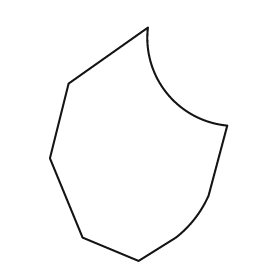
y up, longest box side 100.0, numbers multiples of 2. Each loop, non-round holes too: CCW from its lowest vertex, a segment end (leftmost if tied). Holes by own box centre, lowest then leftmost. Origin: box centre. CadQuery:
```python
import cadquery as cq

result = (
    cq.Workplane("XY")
    .moveTo(0.0, -50.0)
    .lineTo(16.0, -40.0)
    .threePointArc((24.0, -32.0), (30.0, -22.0))
    .lineTo(38.0, 8.0)
    .threePointArc((12.0, 22.0), (4.0, 50.0))
    .lineTo(-30.0, 26.0)
    .lineTo(-38.0, -6.0)
    .lineTo(-24.0, -40.0)
    .close()
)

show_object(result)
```